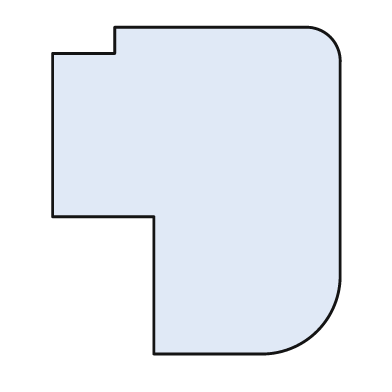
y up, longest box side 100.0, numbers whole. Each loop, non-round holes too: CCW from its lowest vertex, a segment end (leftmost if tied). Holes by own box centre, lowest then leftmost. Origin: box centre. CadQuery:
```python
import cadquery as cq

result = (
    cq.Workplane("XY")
    .moveTo(-13.0, -50.0)
    .lineTo(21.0, -50.0)
    .threePointArc((37.0, -43.0), (44.0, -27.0))
    .lineTo(44.0, 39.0)
    .threePointArc((41.0, 47.0), (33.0, 50.0))
    .lineTo(-25.0, 50.0)
    .lineTo(-25.0, 42.0)
    .lineTo(-44.0, 42.0)
    .lineTo(-44.0, -8.0)
    .lineTo(-13.0, -8.0)
    .close()
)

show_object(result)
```